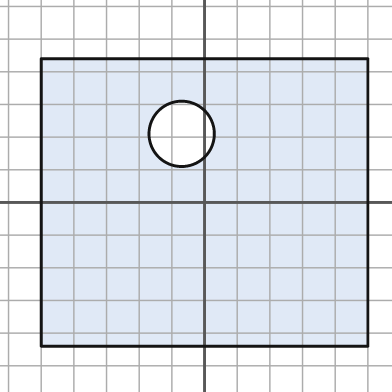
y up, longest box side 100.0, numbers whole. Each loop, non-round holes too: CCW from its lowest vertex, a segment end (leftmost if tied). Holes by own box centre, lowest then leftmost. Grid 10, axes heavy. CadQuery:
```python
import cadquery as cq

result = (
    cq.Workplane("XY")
    .moveTo(-50.0, -44.0)
    .lineTo(50.0, -44.0)
    .lineTo(50.0, 44.0)
    .lineTo(-50.0, 44.0)
    .close()
    .moveTo(-7.0, 21.0)
    .circle(10.0)
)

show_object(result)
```